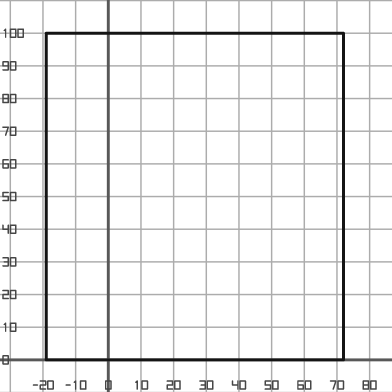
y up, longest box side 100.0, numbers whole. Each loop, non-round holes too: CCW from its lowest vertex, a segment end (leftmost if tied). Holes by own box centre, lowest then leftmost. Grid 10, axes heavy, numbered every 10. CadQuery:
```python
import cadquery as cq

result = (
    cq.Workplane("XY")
    .moveTo(-19.0, 0.0)
    .lineTo(72.0, 0.0)
    .lineTo(72.0, 100.0)
    .lineTo(-19.0, 100.0)
    .close()
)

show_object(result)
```